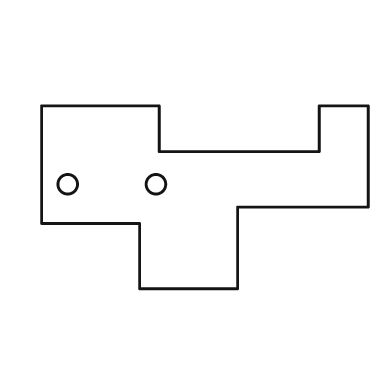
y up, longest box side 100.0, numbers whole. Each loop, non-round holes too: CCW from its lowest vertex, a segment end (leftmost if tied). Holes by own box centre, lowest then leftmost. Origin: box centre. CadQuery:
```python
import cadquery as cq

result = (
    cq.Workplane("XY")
    .moveTo(-20.0, -28.0)
    .lineTo(10.0, -28.0)
    .lineTo(10.0, -3.0)
    .lineTo(50.0, -3.0)
    .lineTo(50.0, 28.0)
    .lineTo(35.0, 28.0)
    .lineTo(35.0, 14.0)
    .lineTo(-14.0, 14.0)
    .lineTo(-14.0, 28.0)
    .lineTo(-50.0, 28.0)
    .lineTo(-50.0, -8.0)
    .lineTo(-20.0, -8.0)
    .close()
    .moveTo(-42.0, 4.0)
    .circle(3.0)
    .moveTo(-15.0, 4.0)
    .circle(3.0)
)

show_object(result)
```